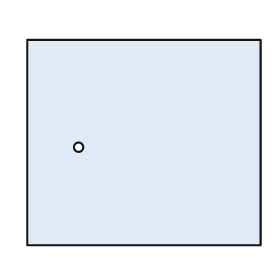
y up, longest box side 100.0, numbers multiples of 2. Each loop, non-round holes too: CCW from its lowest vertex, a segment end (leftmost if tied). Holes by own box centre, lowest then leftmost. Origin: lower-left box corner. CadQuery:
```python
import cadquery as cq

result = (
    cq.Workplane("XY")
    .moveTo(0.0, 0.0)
    .lineTo(100.0, 0.0)
    .lineTo(100.0, 88.0)
    .lineTo(0.0, 88.0)
    .close()
    .moveTo(22.0, 42.0)
    .circle(2.0)
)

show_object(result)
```